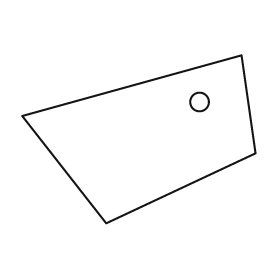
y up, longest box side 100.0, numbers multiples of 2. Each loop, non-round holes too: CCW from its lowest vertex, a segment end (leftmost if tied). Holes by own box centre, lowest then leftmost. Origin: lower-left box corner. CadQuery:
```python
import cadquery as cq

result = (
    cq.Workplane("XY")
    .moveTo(36.0, 0.0)
    .lineTo(100.0, 30.0)
    .lineTo(94.0, 72.0)
    .lineTo(0.0, 46.0)
    .close()
    .moveTo(76.0, 52.0)
    .circle(4.0)
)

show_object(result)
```